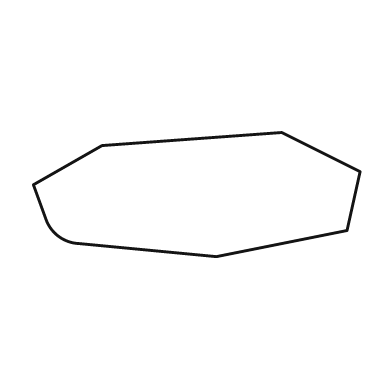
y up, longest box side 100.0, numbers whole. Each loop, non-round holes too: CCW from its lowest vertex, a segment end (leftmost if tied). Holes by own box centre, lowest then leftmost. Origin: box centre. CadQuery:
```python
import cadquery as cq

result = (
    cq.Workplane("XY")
    .moveTo(6.0, -19.0)
    .lineTo(46.0, -11.0)
    .lineTo(50.0, 7.0)
    .lineTo(26.0, 19.0)
    .lineTo(-29.0, 15.0)
    .lineTo(-50.0, 3.0)
    .lineTo(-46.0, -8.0)
    .threePointArc((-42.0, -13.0), (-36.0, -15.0))
    .close()
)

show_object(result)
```